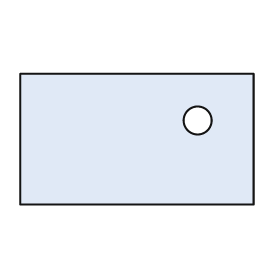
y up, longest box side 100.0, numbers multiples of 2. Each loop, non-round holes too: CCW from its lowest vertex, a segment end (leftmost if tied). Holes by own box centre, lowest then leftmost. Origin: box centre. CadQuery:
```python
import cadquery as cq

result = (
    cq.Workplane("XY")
    .moveTo(-50.0, -28.0)
    .lineTo(50.0, -28.0)
    .lineTo(50.0, 28.0)
    .lineTo(-50.0, 28.0)
    .close()
    .moveTo(26.0, 8.0)
    .circle(6.0)
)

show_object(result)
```